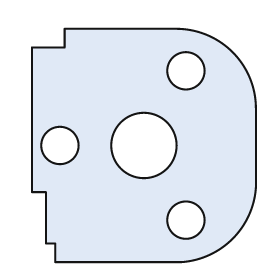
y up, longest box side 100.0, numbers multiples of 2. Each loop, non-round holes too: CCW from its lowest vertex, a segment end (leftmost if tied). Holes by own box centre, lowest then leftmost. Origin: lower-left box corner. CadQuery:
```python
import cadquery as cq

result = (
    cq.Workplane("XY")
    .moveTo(10.0, 0.0)
    .lineTo(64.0, 0.0)
    .threePointArc((86.0, 10.0), (96.0, 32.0))
    .lineTo(96.0, 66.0)
    .threePointArc((86.0, 90.0), (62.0, 100.0))
    .lineTo(14.0, 100.0)
    .lineTo(14.0, 92.0)
    .lineTo(0.0, 92.0)
    .lineTo(0.0, 30.0)
    .lineTo(6.0, 30.0)
    .lineTo(6.0, 8.0)
    .lineTo(10.0, 8.0)
    .close()
    .moveTo(66.0, 18.0)
    .circle(8.0)
    .moveTo(12.0, 50.0)
    .circle(8.0)
    .moveTo(48.0, 50.0)
    .circle(14.0)
    .moveTo(66.0, 82.0)
    .circle(8.0)
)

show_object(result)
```